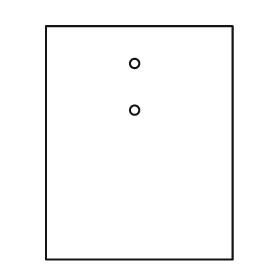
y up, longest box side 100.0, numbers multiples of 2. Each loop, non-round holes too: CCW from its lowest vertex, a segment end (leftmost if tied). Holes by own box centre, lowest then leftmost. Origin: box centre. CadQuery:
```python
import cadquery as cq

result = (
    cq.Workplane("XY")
    .moveTo(-40.0, -50.0)
    .lineTo(40.0, -50.0)
    .lineTo(40.0, 50.0)
    .lineTo(-40.0, 50.0)
    .close()
    .moveTo(-2.0, 14.0)
    .circle(2.0)
    .moveTo(-2.0, 34.0)
    .circle(2.0)
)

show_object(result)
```